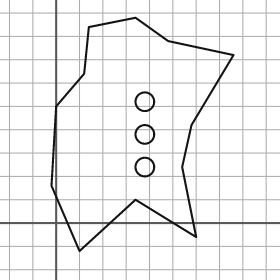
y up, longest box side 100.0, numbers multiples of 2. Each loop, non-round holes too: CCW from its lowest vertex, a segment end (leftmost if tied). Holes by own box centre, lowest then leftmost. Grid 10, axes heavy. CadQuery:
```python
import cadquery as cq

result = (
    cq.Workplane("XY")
    .moveTo(10.0, -12.0)
    .lineTo(34.0, 10.0)
    .lineTo(60.0, -6.0)
    .lineTo(54.0, 24.0)
    .lineTo(58.0, 42.0)
    .lineTo(76.0, 72.0)
    .lineTo(48.0, 78.0)
    .lineTo(34.0, 88.0)
    .lineTo(14.0, 84.0)
    .lineTo(12.0, 64.0)
    .lineTo(0.0, 50.0)
    .lineTo(-2.0, 16.0)
    .close()
    .moveTo(38.0, 24.0)
    .circle(4.0)
    .moveTo(38.0, 38.0)
    .circle(4.0)
    .moveTo(38.0, 52.0)
    .circle(4.0)
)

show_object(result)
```